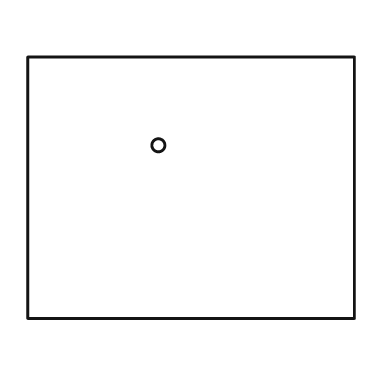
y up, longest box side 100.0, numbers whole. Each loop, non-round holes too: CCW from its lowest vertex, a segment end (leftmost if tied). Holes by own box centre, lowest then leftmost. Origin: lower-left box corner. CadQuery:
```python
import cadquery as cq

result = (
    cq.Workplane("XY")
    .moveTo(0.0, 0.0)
    .lineTo(100.0, 0.0)
    .lineTo(100.0, 80.0)
    .lineTo(0.0, 80.0)
    .close()
    .moveTo(40.0, 53.0)
    .circle(2.0)
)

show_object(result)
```